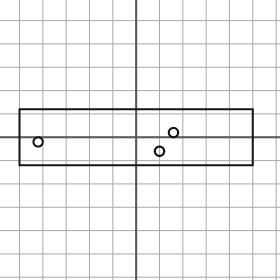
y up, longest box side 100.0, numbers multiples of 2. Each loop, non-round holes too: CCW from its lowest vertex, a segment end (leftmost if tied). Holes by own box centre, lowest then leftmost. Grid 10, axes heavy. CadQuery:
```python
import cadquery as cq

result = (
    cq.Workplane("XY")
    .moveTo(-50.0, -12.0)
    .lineTo(50.0, -12.0)
    .lineTo(50.0, 12.0)
    .lineTo(-50.0, 12.0)
    .close()
    .moveTo(10.0, -6.0)
    .circle(2.0)
    .moveTo(-42.0, -2.0)
    .circle(2.0)
    .moveTo(16.0, 2.0)
    .circle(2.0)
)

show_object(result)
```